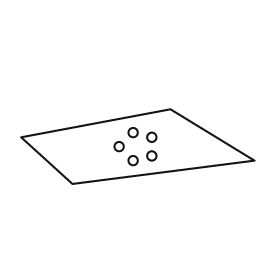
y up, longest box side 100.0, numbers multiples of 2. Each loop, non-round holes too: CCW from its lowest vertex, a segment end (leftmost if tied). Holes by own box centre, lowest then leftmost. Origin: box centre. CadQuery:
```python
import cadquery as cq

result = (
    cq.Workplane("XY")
    .moveTo(-28.0, -16.0)
    .lineTo(50.0, -6.0)
    .lineTo(14.0, 16.0)
    .lineTo(-50.0, 4.0)
    .close()
    .moveTo(-2.0, -6.0)
    .circle(2.0)
    .moveTo(6.0, -4.0)
    .circle(2.0)
    .moveTo(-8.0, 0.0)
    .circle(2.0)
    .moveTo(6.0, 4.0)
    .circle(2.0)
    .moveTo(-2.0, 6.0)
    .circle(2.0)
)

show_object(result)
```